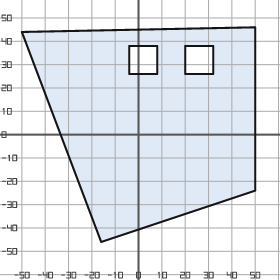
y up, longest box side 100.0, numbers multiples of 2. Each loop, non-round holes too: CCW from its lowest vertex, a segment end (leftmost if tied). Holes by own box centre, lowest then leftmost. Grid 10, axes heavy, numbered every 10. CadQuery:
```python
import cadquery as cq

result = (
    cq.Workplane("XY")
    .moveTo(-16.0, -46.0)
    .lineTo(50.0, -24.0)
    .lineTo(50.0, 46.0)
    .lineTo(-50.0, 44.0)
    .close()
    .moveTo(-4.0, 26.0)
    .lineTo(8.0, 26.0)
    .lineTo(8.0, 38.0)
    .lineTo(-4.0, 38.0)
    .close()
    .moveTo(20.0, 26.0)
    .lineTo(32.0, 26.0)
    .lineTo(32.0, 38.0)
    .lineTo(20.0, 38.0)
    .close()
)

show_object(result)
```